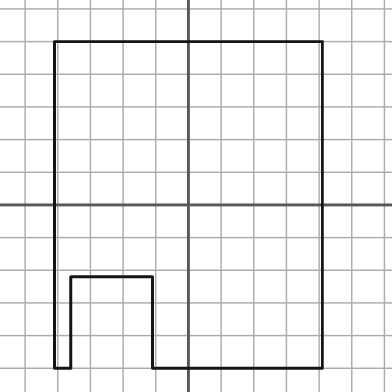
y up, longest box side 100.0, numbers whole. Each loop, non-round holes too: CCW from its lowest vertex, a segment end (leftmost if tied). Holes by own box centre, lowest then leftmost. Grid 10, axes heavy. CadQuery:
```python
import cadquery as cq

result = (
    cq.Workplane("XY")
    .moveTo(-41.0, -50.0)
    .lineTo(-36.0, -50.0)
    .lineTo(-36.0, -22.0)
    .lineTo(-11.0, -22.0)
    .lineTo(-11.0, -50.0)
    .lineTo(41.0, -50.0)
    .lineTo(41.0, 50.0)
    .lineTo(-41.0, 50.0)
    .close()
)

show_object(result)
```